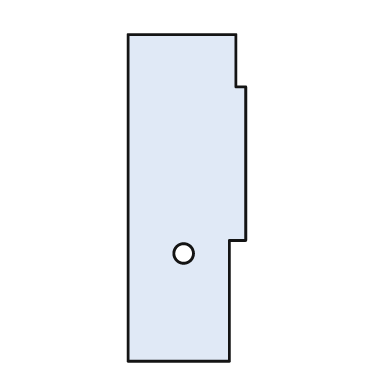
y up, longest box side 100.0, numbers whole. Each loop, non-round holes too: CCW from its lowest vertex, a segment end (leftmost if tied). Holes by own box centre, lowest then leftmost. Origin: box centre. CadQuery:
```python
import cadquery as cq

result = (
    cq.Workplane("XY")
    .moveTo(-18.0, -50.0)
    .lineTo(13.0, -50.0)
    .lineTo(13.0, -13.0)
    .lineTo(18.0, -13.0)
    .lineTo(18.0, 34.0)
    .lineTo(15.0, 34.0)
    .lineTo(15.0, 50.0)
    .lineTo(-18.0, 50.0)
    .close()
    .moveTo(-1.0, -17.0)
    .circle(3.0)
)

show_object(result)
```